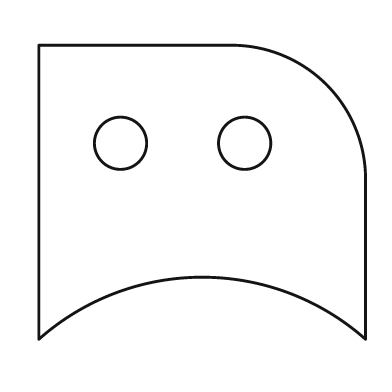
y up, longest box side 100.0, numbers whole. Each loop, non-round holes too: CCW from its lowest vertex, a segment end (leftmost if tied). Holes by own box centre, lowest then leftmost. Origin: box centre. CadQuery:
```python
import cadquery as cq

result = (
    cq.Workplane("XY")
    .moveTo(-50.0, -45.0)
    .threePointArc((0.0, -26.0), (50.0, -45.0))
    .lineTo(50.0, 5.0)
    .threePointArc((38.0, 33.0), (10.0, 45.0))
    .lineTo(-50.0, 45.0)
    .close()
    .moveTo(-25.0, 15.0)
    .circle(8.0)
    .moveTo(13.0, 15.0)
    .circle(8.0)
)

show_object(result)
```